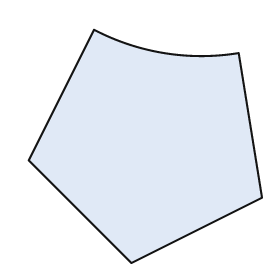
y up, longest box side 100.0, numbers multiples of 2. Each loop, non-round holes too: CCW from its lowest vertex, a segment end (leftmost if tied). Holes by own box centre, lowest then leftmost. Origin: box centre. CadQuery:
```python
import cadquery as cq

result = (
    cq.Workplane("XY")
    .moveTo(-6.0, -50.0)
    .lineTo(50.0, -22.0)
    .lineTo(40.0, 40.0)
    .threePointArc((8.0, 40.0), (-22.0, 50.0))
    .lineTo(-50.0, -6.0)
    .close()
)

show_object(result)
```